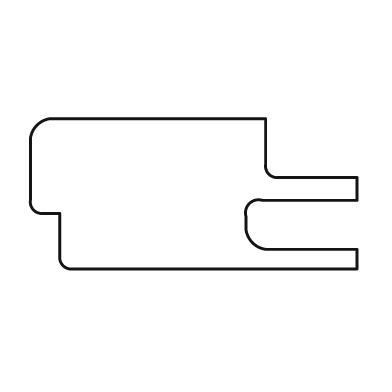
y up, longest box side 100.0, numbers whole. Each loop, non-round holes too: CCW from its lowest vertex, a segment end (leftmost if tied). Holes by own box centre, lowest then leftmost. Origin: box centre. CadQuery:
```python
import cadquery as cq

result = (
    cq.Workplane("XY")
    .moveTo(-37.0, -23.0)
    .lineTo(50.0, -23.0)
    .lineTo(50.0, -17.0)
    .lineTo(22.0, -17.0)
    .threePointArc((18.0, -15.0), (16.0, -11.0))
    .lineTo(16.0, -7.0)
    .threePointArc((17.0, -3.0), (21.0, -2.0))
    .lineTo(50.0, -2.0)
    .lineTo(50.0, 5.0)
    .lineTo(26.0, 5.0)
    .threePointArc((23.0, 6.0), (22.0, 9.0))
    .lineTo(22.0, 23.0)
    .lineTo(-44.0, 23.0)
    .threePointArc((-48.0, 21.0), (-50.0, 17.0))
    .lineTo(-50.0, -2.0)
    .threePointArc((-49.0, -5.0), (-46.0, -6.0))
    .lineTo(-41.0, -6.0)
    .lineTo(-41.0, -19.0)
    .threePointArc((-40.0, -22.0), (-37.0, -23.0))
    .close()
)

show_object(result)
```